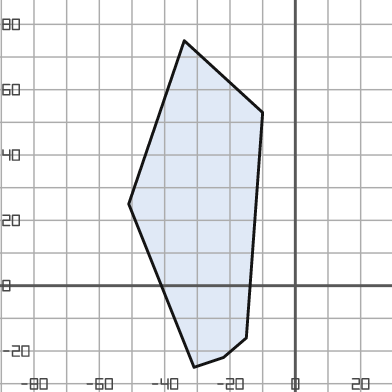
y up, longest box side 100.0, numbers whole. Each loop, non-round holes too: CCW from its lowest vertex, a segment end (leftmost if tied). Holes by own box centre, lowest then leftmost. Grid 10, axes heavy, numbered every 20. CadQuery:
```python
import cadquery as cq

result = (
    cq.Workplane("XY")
    .moveTo(-31.0, -25.0)
    .lineTo(-22.0, -22.0)
    .lineTo(-15.0, -16.0)
    .lineTo(-10.0, 53.0)
    .lineTo(-34.0, 75.0)
    .lineTo(-51.0, 25.0)
    .close()
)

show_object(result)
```